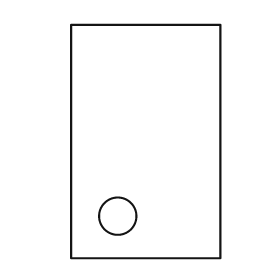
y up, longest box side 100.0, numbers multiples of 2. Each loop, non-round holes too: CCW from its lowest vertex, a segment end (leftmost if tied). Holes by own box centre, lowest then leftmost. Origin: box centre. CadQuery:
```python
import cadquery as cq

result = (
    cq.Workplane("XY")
    .moveTo(-32.0, -50.0)
    .lineTo(32.0, -50.0)
    .lineTo(32.0, 50.0)
    .lineTo(-32.0, 50.0)
    .close()
    .moveTo(-12.0, -32.0)
    .circle(8.0)
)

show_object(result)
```